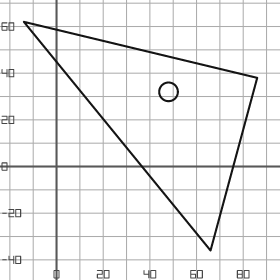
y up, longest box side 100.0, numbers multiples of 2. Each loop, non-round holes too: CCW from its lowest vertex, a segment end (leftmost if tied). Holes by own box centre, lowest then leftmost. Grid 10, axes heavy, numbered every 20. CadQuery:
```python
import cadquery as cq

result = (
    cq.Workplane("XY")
    .moveTo(66.0, -36.0)
    .lineTo(86.0, 38.0)
    .lineTo(-14.0, 62.0)
    .close()
    .moveTo(48.0, 32.0)
    .circle(4.0)
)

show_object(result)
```